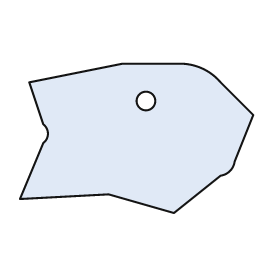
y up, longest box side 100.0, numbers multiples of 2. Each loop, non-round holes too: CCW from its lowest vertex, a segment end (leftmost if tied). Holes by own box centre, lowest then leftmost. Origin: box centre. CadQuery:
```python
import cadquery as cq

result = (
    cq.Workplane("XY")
    .moveTo(16.0, -32.0)
    .lineTo(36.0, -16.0)
    .threePointArc((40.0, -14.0), (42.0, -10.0))
    .lineTo(50.0, 10.0)
    .lineTo(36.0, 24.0)
    .threePointArc((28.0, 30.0), (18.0, 32.0))
    .lineTo(-6.0, 32.0)
    .lineTo(-46.0, 24.0)
    .lineTo(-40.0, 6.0)
    .threePointArc((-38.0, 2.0), (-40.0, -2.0))
    .lineTo(-50.0, -26.0)
    .lineTo(-12.0, -24.0)
    .close()
    .moveTo(4.0, 16.0)
    .circle(4.0)
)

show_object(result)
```